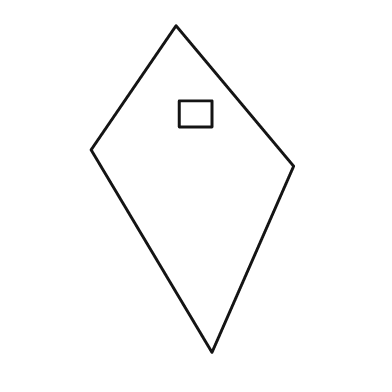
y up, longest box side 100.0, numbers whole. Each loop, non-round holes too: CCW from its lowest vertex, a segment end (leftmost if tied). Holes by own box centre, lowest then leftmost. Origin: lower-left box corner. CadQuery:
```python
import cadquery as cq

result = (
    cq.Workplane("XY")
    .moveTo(37.0, 0.0)
    .lineTo(62.0, 57.0)
    .lineTo(26.0, 100.0)
    .lineTo(0.0, 62.0)
    .close()
    .moveTo(27.0, 69.0)
    .lineTo(37.0, 69.0)
    .lineTo(37.0, 77.0)
    .lineTo(27.0, 77.0)
    .close()
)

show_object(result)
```